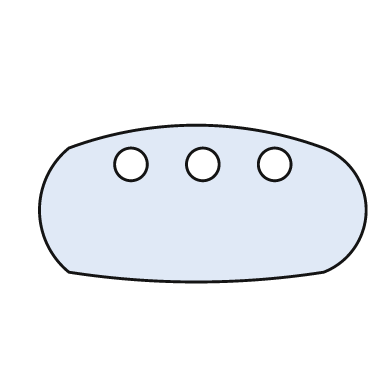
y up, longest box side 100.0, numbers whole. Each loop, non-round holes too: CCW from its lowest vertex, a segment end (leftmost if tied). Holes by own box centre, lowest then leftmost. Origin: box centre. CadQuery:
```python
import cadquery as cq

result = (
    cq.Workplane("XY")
    .moveTo(-41.0, -21.0)
    .threePointArc((-2.0, -24.0), (37.0, -21.0))
    .threePointArc((50.0, -2.0), (37.0, 17.0))
    .threePointArc((-2.0, 24.0), (-41.0, 17.0))
    .threePointArc((-50.0, -2.0), (-41.0, -21.0))
    .close()
    .moveTo(-22.0, 12.0)
    .circle(5.0)
    .moveTo(0.0, 12.0)
    .circle(5.0)
    .moveTo(22.0, 12.0)
    .circle(5.0)
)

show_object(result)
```